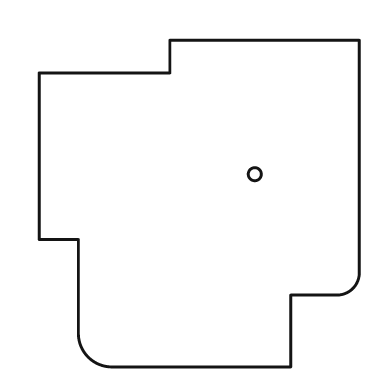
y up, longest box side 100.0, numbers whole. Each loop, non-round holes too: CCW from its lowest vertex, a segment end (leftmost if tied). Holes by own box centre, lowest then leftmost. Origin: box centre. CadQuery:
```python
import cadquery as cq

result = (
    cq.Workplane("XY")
    .moveTo(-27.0, -50.0)
    .lineTo(28.0, -50.0)
    .lineTo(28.0, -28.0)
    .lineTo(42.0, -28.0)
    .threePointArc((47.0, -26.0), (49.0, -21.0))
    .lineTo(49.0, 50.0)
    .lineTo(-9.0, 50.0)
    .lineTo(-9.0, 40.0)
    .lineTo(-49.0, 40.0)
    .lineTo(-49.0, -11.0)
    .lineTo(-37.0, -11.0)
    .lineTo(-37.0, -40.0)
    .threePointArc((-34.0, -47.0), (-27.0, -50.0))
    .close()
    .moveTo(17.0, 9.0)
    .circle(2.0)
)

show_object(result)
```